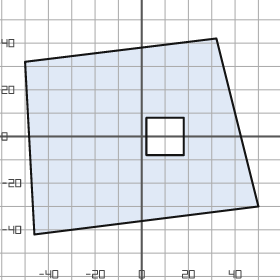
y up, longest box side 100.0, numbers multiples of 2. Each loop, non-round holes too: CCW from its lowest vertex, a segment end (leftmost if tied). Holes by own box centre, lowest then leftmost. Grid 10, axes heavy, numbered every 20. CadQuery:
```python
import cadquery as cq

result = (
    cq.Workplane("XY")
    .moveTo(-46.0, -42.0)
    .lineTo(50.0, -30.0)
    .lineTo(32.0, 42.0)
    .lineTo(-50.0, 32.0)
    .close()
    .moveTo(2.0, -8.0)
    .lineTo(18.0, -8.0)
    .lineTo(18.0, 8.0)
    .lineTo(2.0, 8.0)
    .close()
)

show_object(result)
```